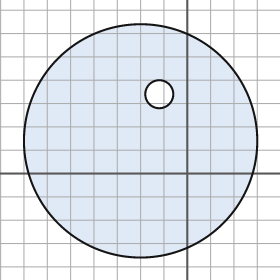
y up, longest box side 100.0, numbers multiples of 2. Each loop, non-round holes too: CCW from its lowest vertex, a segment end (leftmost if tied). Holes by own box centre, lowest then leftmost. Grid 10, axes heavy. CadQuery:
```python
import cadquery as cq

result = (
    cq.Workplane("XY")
    .moveTo(-20.0, 14.0)
    .circle(50.0)
    .moveTo(-12.0, 34.0)
    .circle(6.0)
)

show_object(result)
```